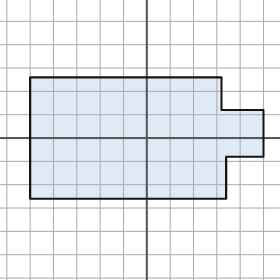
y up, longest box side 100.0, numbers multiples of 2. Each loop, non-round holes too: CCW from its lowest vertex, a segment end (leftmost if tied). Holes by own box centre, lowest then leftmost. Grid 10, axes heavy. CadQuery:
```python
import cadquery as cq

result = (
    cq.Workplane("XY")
    .moveTo(-50.0, -26.0)
    .lineTo(34.0, -26.0)
    .lineTo(34.0, -8.0)
    .lineTo(50.0, -8.0)
    .lineTo(50.0, 12.0)
    .lineTo(32.0, 12.0)
    .lineTo(32.0, 26.0)
    .lineTo(-50.0, 26.0)
    .close()
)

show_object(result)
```